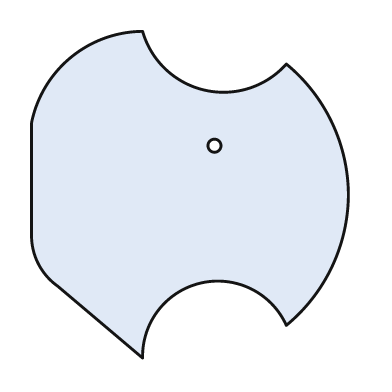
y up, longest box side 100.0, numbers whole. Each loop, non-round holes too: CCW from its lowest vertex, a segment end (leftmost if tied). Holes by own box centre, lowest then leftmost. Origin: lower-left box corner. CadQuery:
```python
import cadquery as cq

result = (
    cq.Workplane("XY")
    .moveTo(34.0, 0.0)
    .threePointArc((52.0, 23.0), (78.0, 10.0))
    .threePointArc((92.0, 28.0), (97.0, 50.0))
    .threePointArc((92.0, 72.0), (78.0, 90.0))
    .threePointArc((53.0, 82.0), (34.0, 100.0))
    .threePointArc((12.0, 92.0), (0.0, 72.0))
    .lineTo(0.0, 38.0)
    .threePointArc((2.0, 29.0), (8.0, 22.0))
    .close()
    .moveTo(56.0, 65.0)
    .circle(2.0)
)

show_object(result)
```